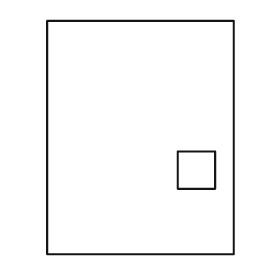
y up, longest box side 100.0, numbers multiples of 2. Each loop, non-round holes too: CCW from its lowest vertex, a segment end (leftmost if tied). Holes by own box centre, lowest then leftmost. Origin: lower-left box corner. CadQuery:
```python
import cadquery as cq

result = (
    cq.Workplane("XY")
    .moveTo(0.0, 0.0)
    .lineTo(80.0, 0.0)
    .lineTo(80.0, 100.0)
    .lineTo(0.0, 100.0)
    .close()
    .moveTo(56.0, 28.0)
    .lineTo(72.0, 28.0)
    .lineTo(72.0, 44.0)
    .lineTo(56.0, 44.0)
    .close()
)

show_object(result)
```